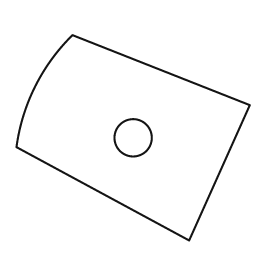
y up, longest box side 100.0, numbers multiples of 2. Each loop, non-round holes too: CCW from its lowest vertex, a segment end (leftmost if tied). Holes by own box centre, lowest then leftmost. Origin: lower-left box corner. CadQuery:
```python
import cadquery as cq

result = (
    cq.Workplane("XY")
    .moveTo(74.0, 0.0)
    .lineTo(100.0, 58.0)
    .lineTo(24.0, 88.0)
    .threePointArc((8.0, 66.0), (0.0, 40.0))
    .close()
    .moveTo(50.0, 44.0)
    .circle(8.0)
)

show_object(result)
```